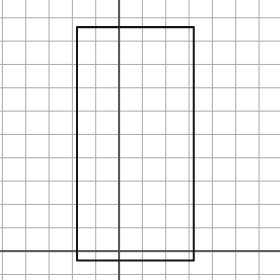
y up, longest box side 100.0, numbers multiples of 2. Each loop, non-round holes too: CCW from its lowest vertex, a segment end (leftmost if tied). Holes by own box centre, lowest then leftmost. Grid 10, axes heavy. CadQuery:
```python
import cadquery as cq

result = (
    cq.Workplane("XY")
    .moveTo(-18.0, -4.0)
    .lineTo(32.0, -4.0)
    .lineTo(32.0, 96.0)
    .lineTo(-18.0, 96.0)
    .close()
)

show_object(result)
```